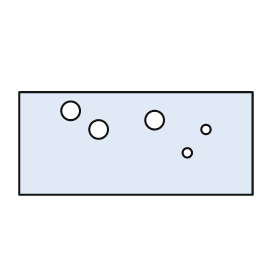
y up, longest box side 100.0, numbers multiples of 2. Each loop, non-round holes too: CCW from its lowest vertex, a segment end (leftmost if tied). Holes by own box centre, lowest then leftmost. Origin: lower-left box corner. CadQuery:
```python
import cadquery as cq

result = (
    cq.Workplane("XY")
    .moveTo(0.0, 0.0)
    .lineTo(100.0, 0.0)
    .lineTo(100.0, 44.0)
    .lineTo(0.0, 44.0)
    .close()
    .moveTo(72.0, 18.0)
    .circle(2.0)
    .moveTo(34.0, 28.0)
    .circle(4.0)
    .moveTo(80.0, 28.0)
    .circle(2.0)
    .moveTo(58.0, 32.0)
    .circle(4.0)
    .moveTo(22.0, 36.0)
    .circle(4.0)
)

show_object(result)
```